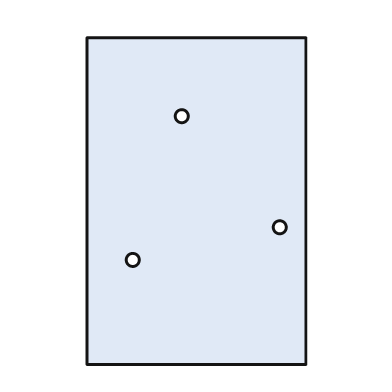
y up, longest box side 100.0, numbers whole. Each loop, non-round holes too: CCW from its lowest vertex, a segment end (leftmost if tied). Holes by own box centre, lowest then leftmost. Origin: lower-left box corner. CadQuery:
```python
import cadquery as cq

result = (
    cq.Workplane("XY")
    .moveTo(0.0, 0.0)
    .lineTo(67.0, 0.0)
    .lineTo(67.0, 100.0)
    .lineTo(0.0, 100.0)
    .close()
    .moveTo(14.0, 32.0)
    .circle(2.0)
    .moveTo(59.0, 42.0)
    .circle(2.0)
    .moveTo(29.0, 76.0)
    .circle(2.0)
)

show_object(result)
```